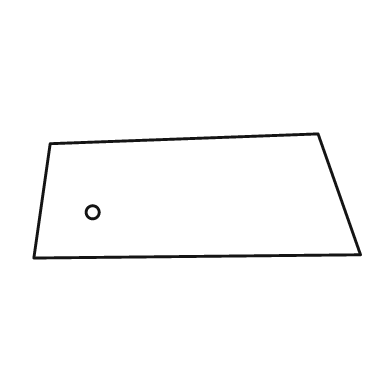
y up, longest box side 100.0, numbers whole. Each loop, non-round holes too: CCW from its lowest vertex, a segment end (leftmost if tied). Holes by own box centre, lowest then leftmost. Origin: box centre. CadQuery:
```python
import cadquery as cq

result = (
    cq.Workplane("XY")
    .moveTo(-50.0, -19.0)
    .lineTo(50.0, -18.0)
    .lineTo(37.0, 19.0)
    .lineTo(-45.0, 16.0)
    .close()
    .moveTo(-32.0, -5.0)
    .circle(2.0)
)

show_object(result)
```